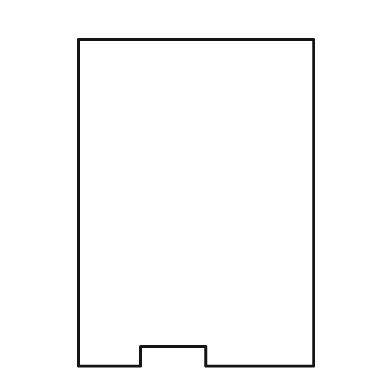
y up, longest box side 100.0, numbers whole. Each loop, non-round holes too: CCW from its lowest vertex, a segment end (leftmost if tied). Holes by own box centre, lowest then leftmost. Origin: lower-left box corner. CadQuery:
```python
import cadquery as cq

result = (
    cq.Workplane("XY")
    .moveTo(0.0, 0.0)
    .lineTo(19.0, 0.0)
    .lineTo(19.0, 6.0)
    .lineTo(39.0, 6.0)
    .lineTo(39.0, 0.0)
    .lineTo(72.0, 0.0)
    .lineTo(72.0, 100.0)
    .lineTo(0.0, 100.0)
    .close()
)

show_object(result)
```